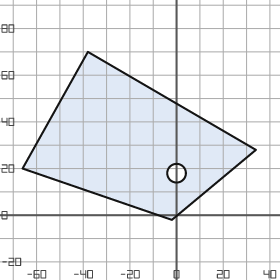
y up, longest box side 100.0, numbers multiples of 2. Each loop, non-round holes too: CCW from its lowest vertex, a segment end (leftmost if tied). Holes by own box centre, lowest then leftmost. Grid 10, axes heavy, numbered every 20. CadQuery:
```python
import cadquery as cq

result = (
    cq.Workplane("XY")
    .moveTo(-2.0, -2.0)
    .lineTo(34.0, 28.0)
    .lineTo(-38.0, 70.0)
    .lineTo(-66.0, 20.0)
    .close()
    .moveTo(0.0, 18.0)
    .circle(4.0)
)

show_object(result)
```